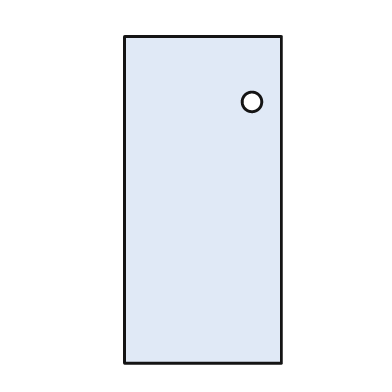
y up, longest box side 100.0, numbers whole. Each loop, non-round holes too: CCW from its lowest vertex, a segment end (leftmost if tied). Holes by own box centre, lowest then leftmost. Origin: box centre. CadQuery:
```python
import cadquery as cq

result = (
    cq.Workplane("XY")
    .moveTo(-24.0, -50.0)
    .lineTo(24.0, -50.0)
    .lineTo(24.0, 50.0)
    .lineTo(-24.0, 50.0)
    .close()
    .moveTo(15.0, 30.0)
    .circle(3.0)
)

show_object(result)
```